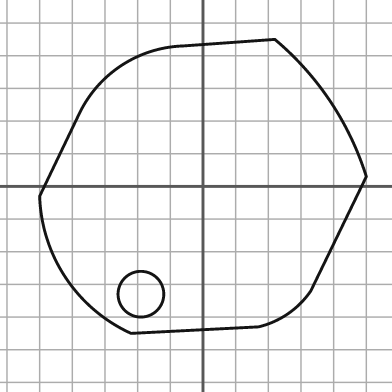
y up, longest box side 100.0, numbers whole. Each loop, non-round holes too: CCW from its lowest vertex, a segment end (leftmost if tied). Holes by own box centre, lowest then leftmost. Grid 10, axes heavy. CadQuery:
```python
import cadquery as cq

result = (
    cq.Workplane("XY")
    .moveTo(-22.0, -45.0)
    .lineTo(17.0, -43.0)
    .threePointArc((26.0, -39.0), (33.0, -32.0))
    .lineTo(50.0, 3.0)
    .threePointArc((39.0, 26.0), (22.0, 45.0))
    .lineTo(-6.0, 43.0)
    .threePointArc((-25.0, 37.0), (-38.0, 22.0))
    .lineTo(-50.0, -3.0)
    .threePointArc((-42.0, -28.0), (-22.0, -45.0))
    .close()
    .moveTo(-19.0, -33.0)
    .circle(7.0)
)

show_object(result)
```